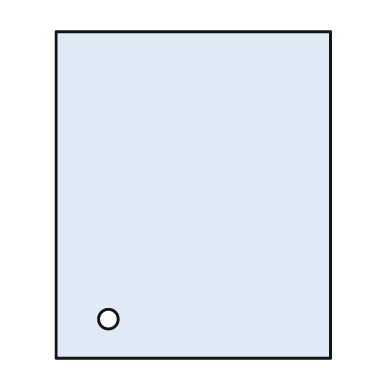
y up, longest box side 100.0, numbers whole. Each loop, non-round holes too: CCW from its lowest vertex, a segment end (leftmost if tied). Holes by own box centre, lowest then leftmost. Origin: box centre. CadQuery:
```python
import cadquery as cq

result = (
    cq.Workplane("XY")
    .moveTo(-42.0, -50.0)
    .lineTo(42.0, -50.0)
    .lineTo(42.0, 50.0)
    .lineTo(-42.0, 50.0)
    .close()
    .moveTo(-26.0, -38.0)
    .circle(3.0)
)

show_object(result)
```